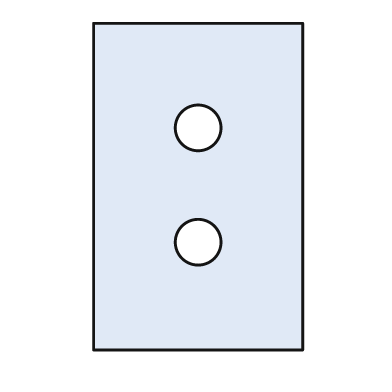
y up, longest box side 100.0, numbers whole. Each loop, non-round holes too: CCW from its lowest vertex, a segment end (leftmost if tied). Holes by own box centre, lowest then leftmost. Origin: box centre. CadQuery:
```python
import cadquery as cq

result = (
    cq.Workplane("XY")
    .moveTo(-32.0, -50.0)
    .lineTo(32.0, -50.0)
    .lineTo(32.0, 50.0)
    .lineTo(-32.0, 50.0)
    .close()
    .moveTo(0.0, -17.0)
    .circle(7.0)
    .moveTo(0.0, 18.0)
    .circle(7.0)
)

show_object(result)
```